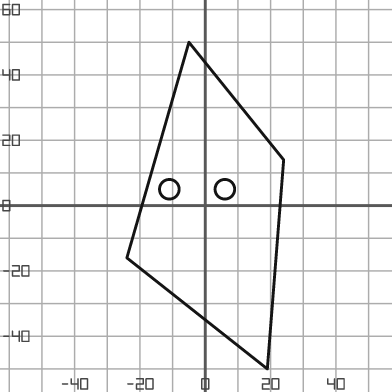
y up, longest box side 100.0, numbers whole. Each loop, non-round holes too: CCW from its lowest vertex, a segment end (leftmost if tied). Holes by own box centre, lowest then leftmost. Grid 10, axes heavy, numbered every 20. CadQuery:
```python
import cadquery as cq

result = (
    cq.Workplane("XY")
    .moveTo(19.0, -50.0)
    .lineTo(24.0, 14.0)
    .lineTo(-5.0, 50.0)
    .lineTo(-24.0, -16.0)
    .close()
    .moveTo(-11.0, 5.0)
    .circle(3.0)
    .moveTo(6.0, 5.0)
    .circle(3.0)
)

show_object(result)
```